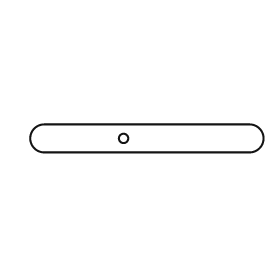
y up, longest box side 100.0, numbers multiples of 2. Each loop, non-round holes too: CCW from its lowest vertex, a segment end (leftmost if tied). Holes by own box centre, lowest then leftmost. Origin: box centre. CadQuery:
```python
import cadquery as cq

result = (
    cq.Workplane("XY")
    .moveTo(-44.0, -6.0)
    .lineTo(44.0, -6.0)
    .threePointArc((50.0, 0.0), (44.0, 6.0))
    .lineTo(-44.0, 6.0)
    .threePointArc((-50.0, 0.0), (-44.0, -6.0))
    .close()
    .moveTo(-10.0, 0.0)
    .circle(2.0)
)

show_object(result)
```